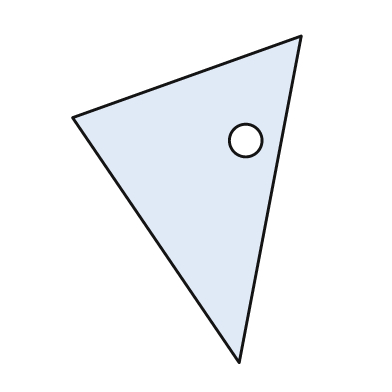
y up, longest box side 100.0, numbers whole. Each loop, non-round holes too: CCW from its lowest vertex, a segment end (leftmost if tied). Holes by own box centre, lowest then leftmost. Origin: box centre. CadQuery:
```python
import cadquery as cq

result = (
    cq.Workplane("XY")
    .moveTo(16.0, -50.0)
    .lineTo(35.0, 50.0)
    .lineTo(-35.0, 25.0)
    .close()
    .moveTo(18.0, 18.0)
    .circle(5.0)
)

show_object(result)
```